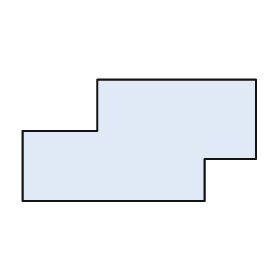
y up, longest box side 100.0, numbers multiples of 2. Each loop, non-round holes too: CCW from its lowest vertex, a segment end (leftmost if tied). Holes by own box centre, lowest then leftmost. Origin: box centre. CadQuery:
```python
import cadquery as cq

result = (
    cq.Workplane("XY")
    .moveTo(-50.0, -26.0)
    .lineTo(28.0, -26.0)
    .lineTo(28.0, -8.0)
    .lineTo(50.0, -8.0)
    .lineTo(50.0, 26.0)
    .lineTo(-18.0, 26.0)
    .lineTo(-18.0, 4.0)
    .lineTo(-50.0, 4.0)
    .close()
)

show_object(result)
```